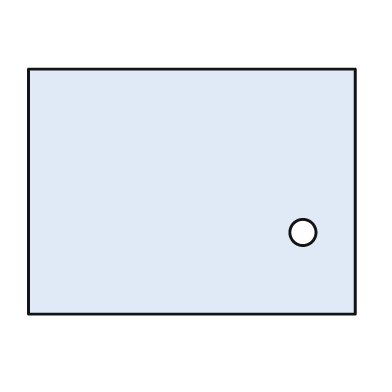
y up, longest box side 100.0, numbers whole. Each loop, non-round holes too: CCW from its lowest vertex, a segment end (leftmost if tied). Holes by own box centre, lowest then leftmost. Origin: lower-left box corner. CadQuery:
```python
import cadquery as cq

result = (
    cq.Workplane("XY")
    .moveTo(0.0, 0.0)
    .lineTo(100.0, 0.0)
    .lineTo(100.0, 75.0)
    .lineTo(0.0, 75.0)
    .close()
    .moveTo(84.0, 25.0)
    .circle(4.0)
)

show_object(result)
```